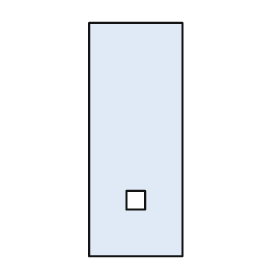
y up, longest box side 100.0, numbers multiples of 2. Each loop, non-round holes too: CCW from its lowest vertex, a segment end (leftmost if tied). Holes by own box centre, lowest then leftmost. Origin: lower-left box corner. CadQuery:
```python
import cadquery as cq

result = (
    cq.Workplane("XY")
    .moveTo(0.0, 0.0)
    .lineTo(40.0, 0.0)
    .lineTo(40.0, 100.0)
    .lineTo(0.0, 100.0)
    .close()
    .moveTo(16.0, 20.0)
    .lineTo(24.0, 20.0)
    .lineTo(24.0, 28.0)
    .lineTo(16.0, 28.0)
    .close()
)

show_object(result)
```